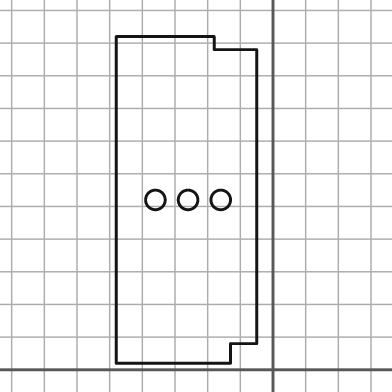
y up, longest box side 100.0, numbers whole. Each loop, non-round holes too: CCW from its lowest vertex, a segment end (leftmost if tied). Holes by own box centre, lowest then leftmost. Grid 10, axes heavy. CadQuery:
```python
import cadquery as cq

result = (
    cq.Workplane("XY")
    .moveTo(-48.0, 2.0)
    .lineTo(-13.0, 2.0)
    .lineTo(-13.0, 8.0)
    .lineTo(-5.0, 8.0)
    .lineTo(-5.0, 98.0)
    .lineTo(-18.0, 98.0)
    .lineTo(-18.0, 102.0)
    .lineTo(-48.0, 102.0)
    .close()
    .moveTo(-36.0, 52.0)
    .circle(3.0)
    .moveTo(-26.0, 52.0)
    .circle(3.0)
    .moveTo(-16.0, 52.0)
    .circle(3.0)
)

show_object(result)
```